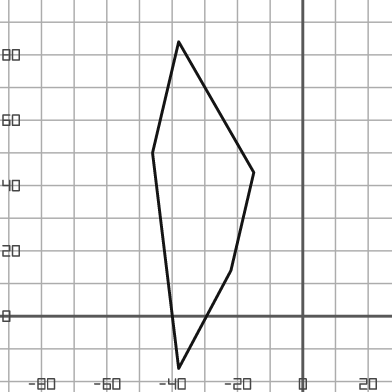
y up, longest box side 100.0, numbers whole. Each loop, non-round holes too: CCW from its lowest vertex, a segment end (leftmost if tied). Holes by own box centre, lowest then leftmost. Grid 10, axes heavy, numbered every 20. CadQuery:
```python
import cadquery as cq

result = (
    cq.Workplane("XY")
    .moveTo(-38.0, -16.0)
    .lineTo(-22.0, 14.0)
    .lineTo(-15.0, 44.0)
    .lineTo(-38.0, 84.0)
    .lineTo(-46.0, 50.0)
    .close()
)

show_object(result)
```